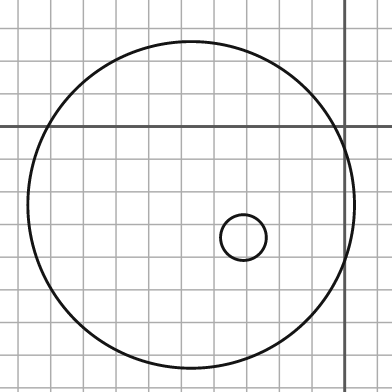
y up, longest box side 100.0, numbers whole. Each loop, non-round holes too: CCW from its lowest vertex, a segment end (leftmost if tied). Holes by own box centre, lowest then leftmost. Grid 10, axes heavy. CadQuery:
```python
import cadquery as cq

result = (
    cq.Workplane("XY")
    .moveTo(-47.0, -24.0)
    .circle(50.0)
    .moveTo(-31.0, -34.0)
    .circle(7.0)
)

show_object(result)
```